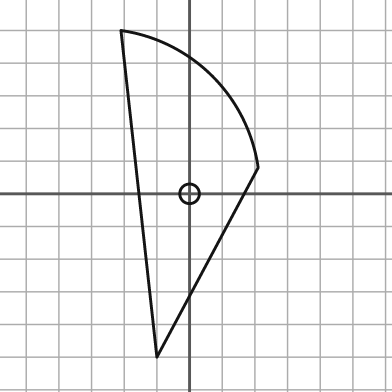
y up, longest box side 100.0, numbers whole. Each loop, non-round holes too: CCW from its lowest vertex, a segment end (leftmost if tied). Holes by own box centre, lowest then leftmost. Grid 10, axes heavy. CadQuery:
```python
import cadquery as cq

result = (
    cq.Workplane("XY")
    .moveTo(-10.0, -50.0)
    .lineTo(21.0, 8.0)
    .threePointArc((7.0, 36.0), (-21.0, 50.0))
    .close()
    .moveTo(0.0, 0.0)
    .circle(3.0)
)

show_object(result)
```